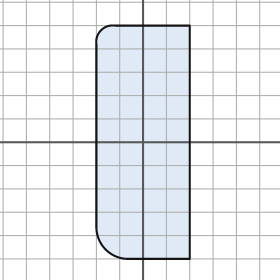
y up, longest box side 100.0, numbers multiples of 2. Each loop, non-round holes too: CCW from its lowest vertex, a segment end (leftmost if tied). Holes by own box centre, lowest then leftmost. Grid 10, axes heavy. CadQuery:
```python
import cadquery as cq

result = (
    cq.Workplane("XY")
    .moveTo(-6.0, -50.0)
    .lineTo(20.0, -50.0)
    .lineTo(20.0, 50.0)
    .lineTo(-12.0, 50.0)
    .threePointArc((-18.0, 48.0), (-20.0, 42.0))
    .lineTo(-20.0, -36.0)
    .threePointArc((-16.0, -46.0), (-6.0, -50.0))
    .close()
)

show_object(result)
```